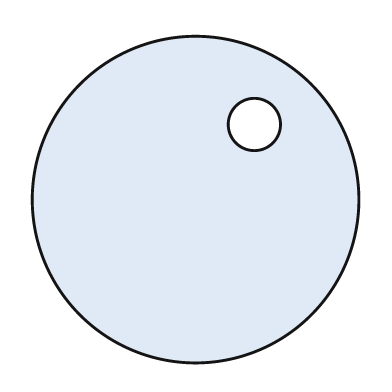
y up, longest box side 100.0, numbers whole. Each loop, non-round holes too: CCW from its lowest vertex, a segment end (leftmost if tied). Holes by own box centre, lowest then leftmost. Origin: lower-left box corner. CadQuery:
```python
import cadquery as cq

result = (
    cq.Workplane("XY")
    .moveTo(50.0, 50.0)
    .circle(50.0)
    .moveTo(68.0, 73.0)
    .circle(8.0)
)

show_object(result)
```